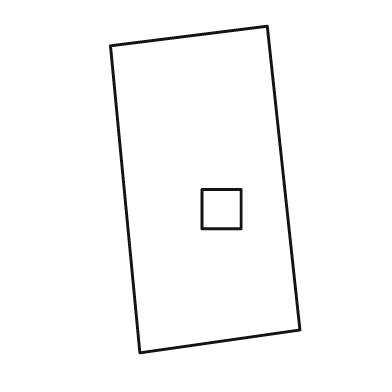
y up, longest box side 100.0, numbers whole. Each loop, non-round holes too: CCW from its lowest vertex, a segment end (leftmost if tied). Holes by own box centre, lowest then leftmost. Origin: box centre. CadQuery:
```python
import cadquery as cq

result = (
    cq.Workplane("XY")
    .moveTo(-20.0, -50.0)
    .lineTo(29.0, -43.0)
    .lineTo(19.0, 50.0)
    .lineTo(-29.0, 44.0)
    .close()
    .moveTo(-1.0, -12.0)
    .lineTo(11.0, -12.0)
    .lineTo(11.0, 0.0)
    .lineTo(-1.0, 0.0)
    .close()
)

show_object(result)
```